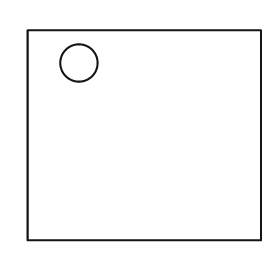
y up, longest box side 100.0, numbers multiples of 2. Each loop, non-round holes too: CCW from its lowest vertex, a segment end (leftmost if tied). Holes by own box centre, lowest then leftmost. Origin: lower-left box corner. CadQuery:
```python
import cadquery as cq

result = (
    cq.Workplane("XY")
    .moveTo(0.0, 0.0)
    .lineTo(100.0, 0.0)
    .lineTo(100.0, 90.0)
    .lineTo(0.0, 90.0)
    .close()
    .moveTo(22.0, 76.0)
    .circle(8.0)
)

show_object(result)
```